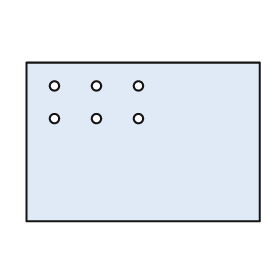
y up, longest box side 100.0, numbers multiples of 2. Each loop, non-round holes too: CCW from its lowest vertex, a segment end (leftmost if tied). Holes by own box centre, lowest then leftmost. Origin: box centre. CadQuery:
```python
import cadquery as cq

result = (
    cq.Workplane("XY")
    .moveTo(-50.0, -34.0)
    .lineTo(50.0, -34.0)
    .lineTo(50.0, 34.0)
    .lineTo(-50.0, 34.0)
    .close()
    .moveTo(-38.0, 10.0)
    .circle(2.0)
    .moveTo(-20.0, 10.0)
    .circle(2.0)
    .moveTo(-2.0, 10.0)
    .circle(2.0)
    .moveTo(-38.0, 24.0)
    .circle(2.0)
    .moveTo(-20.0, 24.0)
    .circle(2.0)
    .moveTo(-2.0, 24.0)
    .circle(2.0)
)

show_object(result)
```